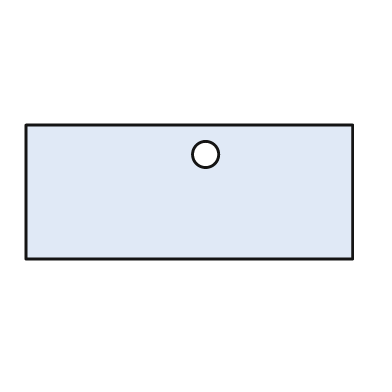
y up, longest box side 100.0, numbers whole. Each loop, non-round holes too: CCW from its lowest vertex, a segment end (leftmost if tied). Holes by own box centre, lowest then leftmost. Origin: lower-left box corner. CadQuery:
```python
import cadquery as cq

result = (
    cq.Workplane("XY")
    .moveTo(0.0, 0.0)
    .lineTo(100.0, 0.0)
    .lineTo(100.0, 41.0)
    .lineTo(0.0, 41.0)
    .close()
    .moveTo(55.0, 32.0)
    .circle(4.0)
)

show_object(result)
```